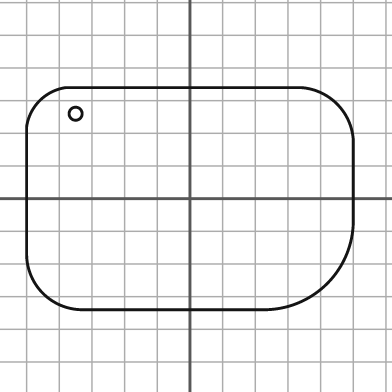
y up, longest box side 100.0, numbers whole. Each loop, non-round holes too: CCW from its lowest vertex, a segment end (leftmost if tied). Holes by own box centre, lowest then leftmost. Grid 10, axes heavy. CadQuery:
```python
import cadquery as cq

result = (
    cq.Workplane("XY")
    .moveTo(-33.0, -34.0)
    .lineTo(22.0, -34.0)
    .threePointArc((42.0, -26.0), (50.0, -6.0))
    .lineTo(50.0, 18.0)
    .threePointArc((45.0, 29.0), (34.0, 34.0))
    .lineTo(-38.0, 34.0)
    .threePointArc((-46.0, 30.0), (-50.0, 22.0))
    .lineTo(-50.0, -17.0)
    .threePointArc((-45.0, -29.0), (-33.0, -34.0))
    .close()
    .moveTo(-35.0, 26.0)
    .circle(2.0)
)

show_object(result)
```